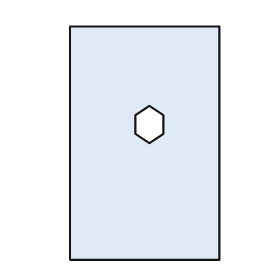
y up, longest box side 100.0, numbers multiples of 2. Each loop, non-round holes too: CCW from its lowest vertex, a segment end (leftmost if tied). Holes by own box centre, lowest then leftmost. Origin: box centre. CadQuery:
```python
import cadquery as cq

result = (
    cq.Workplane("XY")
    .moveTo(-32.0, -50.0)
    .lineTo(32.0, -50.0)
    .lineTo(32.0, 50.0)
    .lineTo(-32.0, 50.0)
    .close()
    .moveTo(2.0, 0.0)
    .lineTo(8.0, 4.0)
    .lineTo(8.0, 12.0)
    .lineTo(2.0, 16.0)
    .lineTo(-4.0, 12.0)
    .lineTo(-4.0, 4.0)
    .close()
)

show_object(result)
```